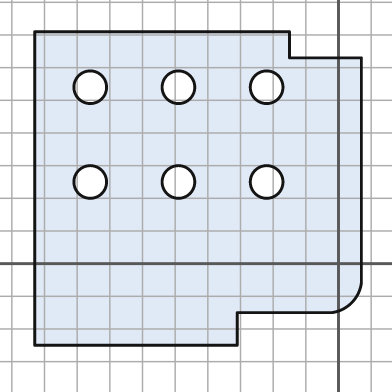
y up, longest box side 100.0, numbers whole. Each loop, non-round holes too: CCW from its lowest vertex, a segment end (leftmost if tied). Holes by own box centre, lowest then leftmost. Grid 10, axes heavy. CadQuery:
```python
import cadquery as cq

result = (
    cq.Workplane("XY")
    .moveTo(-93.0, -25.0)
    .lineTo(-31.0, -25.0)
    .lineTo(-31.0, -15.0)
    .lineTo(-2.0, -15.0)
    .threePointArc((4.0, -12.0), (7.0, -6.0))
    .lineTo(7.0, 63.0)
    .lineTo(-15.0, 63.0)
    .lineTo(-15.0, 71.0)
    .lineTo(-93.0, 71.0)
    .close()
    .moveTo(-76.0, 25.0)
    .circle(5.0)
    .moveTo(-49.0, 25.0)
    .circle(5.0)
    .moveTo(-22.0, 25.0)
    .circle(5.0)
    .moveTo(-76.0, 54.0)
    .circle(5.0)
    .moveTo(-49.0, 54.0)
    .circle(5.0)
    .moveTo(-22.0, 54.0)
    .circle(5.0)
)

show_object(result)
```